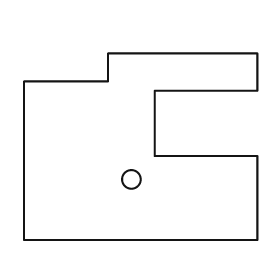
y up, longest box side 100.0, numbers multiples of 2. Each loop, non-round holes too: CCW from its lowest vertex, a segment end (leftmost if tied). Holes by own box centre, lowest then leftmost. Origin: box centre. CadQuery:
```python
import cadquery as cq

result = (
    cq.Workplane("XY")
    .moveTo(-50.0, -40.0)
    .lineTo(50.0, -40.0)
    .lineTo(50.0, -4.0)
    .lineTo(6.0, -4.0)
    .lineTo(6.0, 24.0)
    .lineTo(50.0, 24.0)
    .lineTo(50.0, 40.0)
    .lineTo(-14.0, 40.0)
    .lineTo(-14.0, 28.0)
    .lineTo(-50.0, 28.0)
    .close()
    .moveTo(-4.0, -14.0)
    .circle(4.0)
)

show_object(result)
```